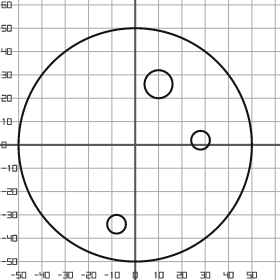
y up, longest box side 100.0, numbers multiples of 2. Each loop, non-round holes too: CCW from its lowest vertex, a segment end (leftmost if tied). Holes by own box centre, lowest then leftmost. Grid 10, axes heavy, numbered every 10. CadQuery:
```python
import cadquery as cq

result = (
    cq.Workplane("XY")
    .moveTo(0.0, 0.0)
    .circle(50.0)
    .moveTo(-8.0, -34.0)
    .circle(4.0)
    .moveTo(28.0, 2.0)
    .circle(4.0)
    .moveTo(10.0, 26.0)
    .circle(6.0)
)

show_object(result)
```